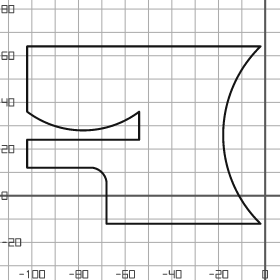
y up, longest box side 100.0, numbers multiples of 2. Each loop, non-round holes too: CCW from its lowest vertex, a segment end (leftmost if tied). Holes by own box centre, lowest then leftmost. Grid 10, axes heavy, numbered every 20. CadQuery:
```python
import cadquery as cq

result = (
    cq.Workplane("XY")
    .moveTo(-68.0, -12.0)
    .lineTo(-2.0, -12.0)
    .threePointArc((-18.0, 26.0), (-2.0, 64.0))
    .lineTo(-102.0, 64.0)
    .lineTo(-102.0, 36.0)
    .threePointArc((-78.0, 28.0), (-54.0, 36.0))
    .lineTo(-54.0, 24.0)
    .lineTo(-102.0, 24.0)
    .lineTo(-102.0, 12.0)
    .lineTo(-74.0, 12.0)
    .threePointArc((-70.0, 10.0), (-68.0, 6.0))
    .close()
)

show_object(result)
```